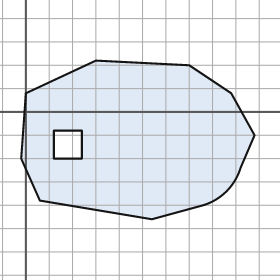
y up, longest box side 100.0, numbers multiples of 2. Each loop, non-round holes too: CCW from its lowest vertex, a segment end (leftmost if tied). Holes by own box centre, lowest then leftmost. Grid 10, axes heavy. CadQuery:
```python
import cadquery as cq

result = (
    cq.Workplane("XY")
    .moveTo(54.0, -46.0)
    .lineTo(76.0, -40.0)
    .threePointArc((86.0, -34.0), (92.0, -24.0))
    .lineTo(98.0, -10.0)
    .lineTo(88.0, 8.0)
    .lineTo(70.0, 20.0)
    .lineTo(30.0, 22.0)
    .lineTo(0.0, 8.0)
    .lineTo(-2.0, -20.0)
    .lineTo(6.0, -38.0)
    .close()
    .moveTo(12.0, -20.0)
    .lineTo(24.0, -20.0)
    .lineTo(24.0, -8.0)
    .lineTo(12.0, -8.0)
    .close()
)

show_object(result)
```